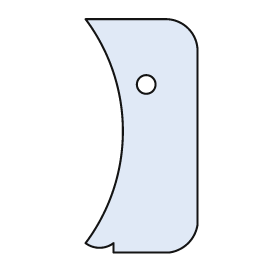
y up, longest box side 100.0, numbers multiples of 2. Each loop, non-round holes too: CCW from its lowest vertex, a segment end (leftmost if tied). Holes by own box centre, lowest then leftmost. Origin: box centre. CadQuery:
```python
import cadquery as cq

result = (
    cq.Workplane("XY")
    .moveTo(-12.0, -50.0)
    .lineTo(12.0, -50.0)
    .threePointArc((20.0, -46.0), (24.0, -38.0))
    .lineTo(24.0, 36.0)
    .threePointArc((20.0, 46.0), (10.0, 50.0))
    .lineTo(-24.0, 50.0)
    .threePointArc((-8.0, 2.0), (-24.0, -46.0))
    .threePointArc((-18.0, -48.0), (-12.0, -46.0))
    .close()
    .moveTo(2.0, 22.0)
    .circle(4.0)
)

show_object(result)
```